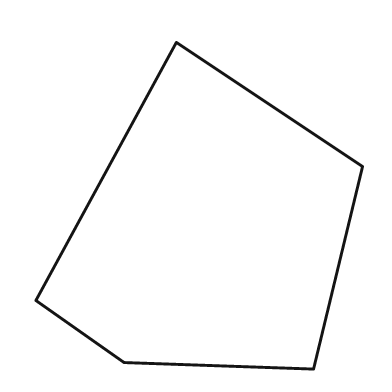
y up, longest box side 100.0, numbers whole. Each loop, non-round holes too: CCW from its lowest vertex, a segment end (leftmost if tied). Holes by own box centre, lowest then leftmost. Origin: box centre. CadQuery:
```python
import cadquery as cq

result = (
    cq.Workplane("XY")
    .moveTo(35.0, -50.0)
    .lineTo(50.0, 12.0)
    .lineTo(-7.0, 50.0)
    .lineTo(-50.0, -29.0)
    .lineTo(-23.0, -48.0)
    .close()
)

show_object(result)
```